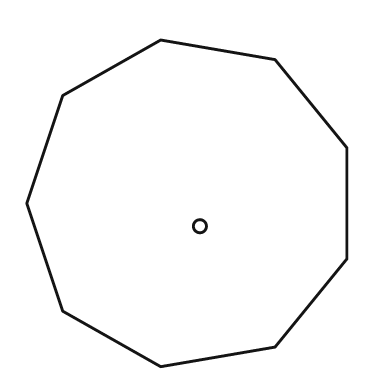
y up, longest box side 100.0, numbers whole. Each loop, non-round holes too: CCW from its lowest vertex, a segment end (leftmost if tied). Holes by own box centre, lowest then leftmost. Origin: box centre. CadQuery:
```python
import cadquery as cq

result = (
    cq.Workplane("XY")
    .moveTo(-8.0, -50.0)
    .lineTo(27.0, -44.0)
    .lineTo(49.0, -17.0)
    .lineTo(49.0, 17.0)
    .lineTo(27.0, 44.0)
    .lineTo(-8.0, 50.0)
    .lineTo(-38.0, 33.0)
    .lineTo(-49.0, 0.0)
    .lineTo(-38.0, -33.0)
    .close()
    .moveTo(4.0, -7.0)
    .circle(2.0)
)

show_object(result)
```